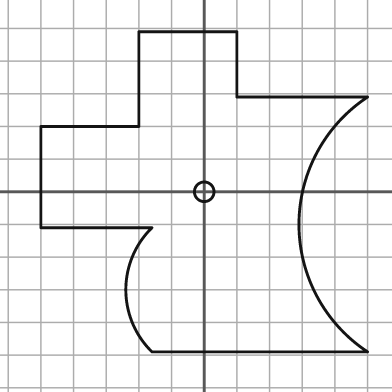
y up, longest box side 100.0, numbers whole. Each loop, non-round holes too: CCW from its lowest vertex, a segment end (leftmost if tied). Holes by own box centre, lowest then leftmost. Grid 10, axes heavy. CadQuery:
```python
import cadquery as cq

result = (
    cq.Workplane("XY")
    .moveTo(-16.0, -49.0)
    .lineTo(50.0, -49.0)
    .threePointArc((29.0, -10.0), (50.0, 29.0))
    .lineTo(10.0, 29.0)
    .lineTo(10.0, 49.0)
    .lineTo(-20.0, 49.0)
    .lineTo(-20.0, 20.0)
    .lineTo(-50.0, 20.0)
    .lineTo(-50.0, -11.0)
    .lineTo(-16.0, -11.0)
    .threePointArc((-24.0, -30.0), (-16.0, -49.0))
    .close()
    .moveTo(0.0, 0.0)
    .circle(3.0)
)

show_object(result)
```